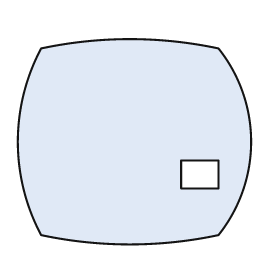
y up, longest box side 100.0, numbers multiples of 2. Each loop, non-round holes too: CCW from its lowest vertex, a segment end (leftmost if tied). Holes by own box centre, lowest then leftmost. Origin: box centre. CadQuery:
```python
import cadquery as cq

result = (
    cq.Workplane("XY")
    .moveTo(-40.0, -40.0)
    .threePointArc((-2.0, -44.0), (36.0, -40.0))
    .threePointArc((50.0, 0.0), (36.0, 40.0))
    .threePointArc((-2.0, 44.0), (-40.0, 40.0))
    .threePointArc((-50.0, 0.0), (-40.0, -40.0))
    .close()
    .moveTo(20.0, -20.0)
    .lineTo(36.0, -20.0)
    .lineTo(36.0, -8.0)
    .lineTo(20.0, -8.0)
    .close()
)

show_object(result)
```